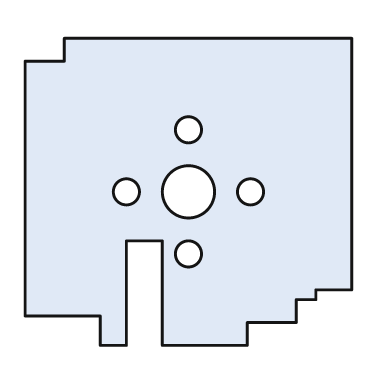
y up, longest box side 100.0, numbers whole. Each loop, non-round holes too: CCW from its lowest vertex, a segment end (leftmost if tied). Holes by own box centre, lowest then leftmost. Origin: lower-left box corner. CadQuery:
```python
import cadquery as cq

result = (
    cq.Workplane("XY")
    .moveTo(23.0, 0.0)
    .lineTo(31.0, 0.0)
    .lineTo(31.0, 32.0)
    .lineTo(42.0, 32.0)
    .lineTo(42.0, 0.0)
    .lineTo(68.0, 0.0)
    .lineTo(68.0, 7.0)
    .lineTo(83.0, 7.0)
    .lineTo(83.0, 14.0)
    .lineTo(89.0, 14.0)
    .lineTo(89.0, 17.0)
    .lineTo(100.0, 17.0)
    .lineTo(100.0, 94.0)
    .lineTo(12.0, 94.0)
    .lineTo(12.0, 87.0)
    .lineTo(0.0, 87.0)
    .lineTo(0.0, 9.0)
    .lineTo(23.0, 9.0)
    .close()
    .moveTo(50.0, 28.0)
    .circle(4.0)
    .moveTo(31.0, 47.0)
    .circle(4.0)
    .moveTo(50.0, 47.0)
    .circle(8.0)
    .moveTo(69.0, 47.0)
    .circle(4.0)
    .moveTo(50.0, 66.0)
    .circle(4.0)
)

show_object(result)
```